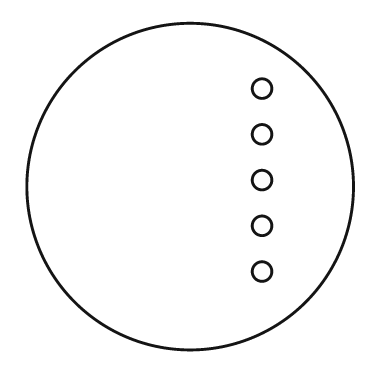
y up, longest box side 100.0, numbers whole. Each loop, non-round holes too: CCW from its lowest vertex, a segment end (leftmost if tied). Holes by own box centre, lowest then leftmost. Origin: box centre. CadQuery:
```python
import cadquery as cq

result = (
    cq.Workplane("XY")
    .moveTo(0.0, 0.0)
    .circle(50.0)
    .moveTo(22.0, -26.0)
    .circle(3.0)
    .moveTo(22.0, -12.0)
    .circle(3.0)
    .moveTo(22.0, 2.0)
    .circle(3.0)
    .moveTo(22.0, 16.0)
    .circle(3.0)
    .moveTo(22.0, 30.0)
    .circle(3.0)
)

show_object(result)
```